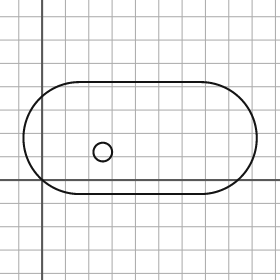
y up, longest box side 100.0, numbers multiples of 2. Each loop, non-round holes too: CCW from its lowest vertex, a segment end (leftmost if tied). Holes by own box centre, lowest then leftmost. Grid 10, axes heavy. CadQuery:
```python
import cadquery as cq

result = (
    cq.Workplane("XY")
    .moveTo(16.0, -6.0)
    .lineTo(68.0, -6.0)
    .threePointArc((92.0, 18.0), (68.0, 42.0))
    .lineTo(16.0, 42.0)
    .threePointArc((-8.0, 18.0), (16.0, -6.0))
    .close()
    .moveTo(26.0, 12.0)
    .circle(4.0)
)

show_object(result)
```